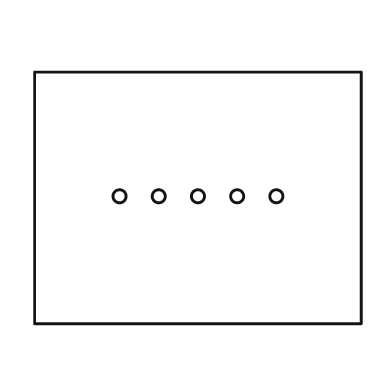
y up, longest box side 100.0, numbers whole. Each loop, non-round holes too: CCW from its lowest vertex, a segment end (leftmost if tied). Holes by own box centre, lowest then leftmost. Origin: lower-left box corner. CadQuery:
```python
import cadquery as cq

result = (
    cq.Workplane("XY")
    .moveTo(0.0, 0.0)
    .lineTo(100.0, 0.0)
    .lineTo(100.0, 77.0)
    .lineTo(0.0, 77.0)
    .close()
    .moveTo(26.0, 39.0)
    .circle(2.0)
    .moveTo(38.0, 39.0)
    .circle(2.0)
    .moveTo(50.0, 39.0)
    .circle(2.0)
    .moveTo(62.0, 39.0)
    .circle(2.0)
    .moveTo(74.0, 39.0)
    .circle(2.0)
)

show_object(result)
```